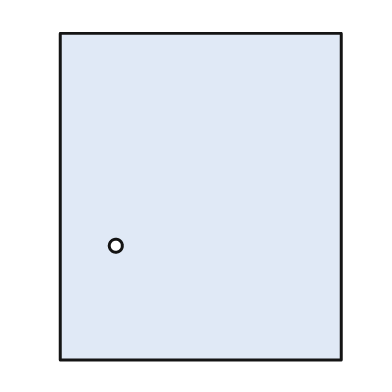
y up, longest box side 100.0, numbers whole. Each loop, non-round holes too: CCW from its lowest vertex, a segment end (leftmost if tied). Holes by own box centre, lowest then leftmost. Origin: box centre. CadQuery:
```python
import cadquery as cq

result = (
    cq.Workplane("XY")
    .moveTo(-43.0, -50.0)
    .lineTo(43.0, -50.0)
    .lineTo(43.0, 50.0)
    .lineTo(-43.0, 50.0)
    .close()
    .moveTo(-26.0, -15.0)
    .circle(2.0)
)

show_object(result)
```